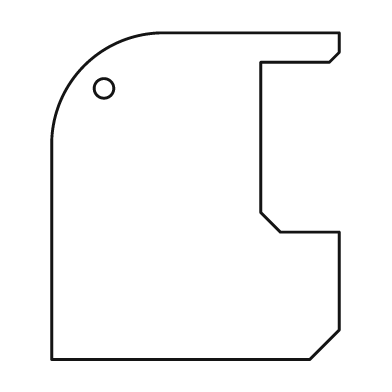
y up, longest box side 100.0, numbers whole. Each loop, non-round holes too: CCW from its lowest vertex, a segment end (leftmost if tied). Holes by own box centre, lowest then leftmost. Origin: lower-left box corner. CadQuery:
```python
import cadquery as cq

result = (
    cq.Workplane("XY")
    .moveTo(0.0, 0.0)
    .lineTo(79.0, 0.0)
    .lineTo(88.0, 9.0)
    .lineTo(88.0, 39.0)
    .lineTo(70.0, 39.0)
    .lineTo(64.0, 45.0)
    .lineTo(64.0, 91.0)
    .lineTo(85.0, 91.0)
    .lineTo(88.0, 94.0)
    .lineTo(88.0, 100.0)
    .lineTo(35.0, 100.0)
    .threePointArc((10.0, 90.0), (0.0, 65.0))
    .close()
    .moveTo(16.0, 83.0)
    .circle(3.0)
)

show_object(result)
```